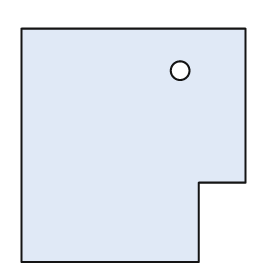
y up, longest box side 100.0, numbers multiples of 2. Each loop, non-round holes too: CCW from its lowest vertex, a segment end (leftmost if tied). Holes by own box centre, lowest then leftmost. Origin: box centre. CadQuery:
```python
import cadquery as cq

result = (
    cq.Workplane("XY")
    .moveTo(-48.0, -50.0)
    .lineTo(28.0, -50.0)
    .lineTo(28.0, -16.0)
    .lineTo(48.0, -16.0)
    .lineTo(48.0, 50.0)
    .lineTo(-48.0, 50.0)
    .close()
    .moveTo(20.0, 32.0)
    .circle(4.0)
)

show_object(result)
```